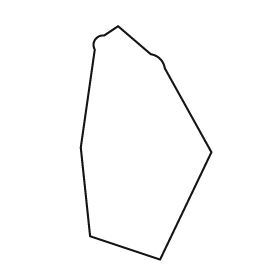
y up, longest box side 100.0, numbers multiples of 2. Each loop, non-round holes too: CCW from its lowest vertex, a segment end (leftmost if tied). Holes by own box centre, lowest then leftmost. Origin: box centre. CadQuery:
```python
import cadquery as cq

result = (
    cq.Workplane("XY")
    .moveTo(6.0, -50.0)
    .lineTo(28.0, -4.0)
    .lineTo(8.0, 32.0)
    .threePointArc((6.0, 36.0), (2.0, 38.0))
    .lineTo(-12.0, 50.0)
    .lineTo(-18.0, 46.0)
    .threePointArc((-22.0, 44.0), (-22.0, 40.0))
    .lineTo(-28.0, -2.0)
    .lineTo(-24.0, -40.0)
    .close()
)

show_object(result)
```